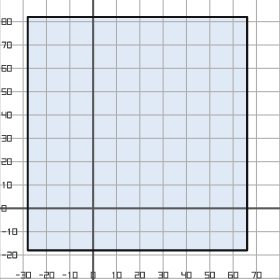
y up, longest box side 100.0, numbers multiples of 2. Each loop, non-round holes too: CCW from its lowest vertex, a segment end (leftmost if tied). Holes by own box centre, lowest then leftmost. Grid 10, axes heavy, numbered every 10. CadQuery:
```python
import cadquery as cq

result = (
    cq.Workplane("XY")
    .moveTo(-28.0, -18.0)
    .lineTo(66.0, -18.0)
    .lineTo(66.0, 82.0)
    .lineTo(-28.0, 82.0)
    .close()
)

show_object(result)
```